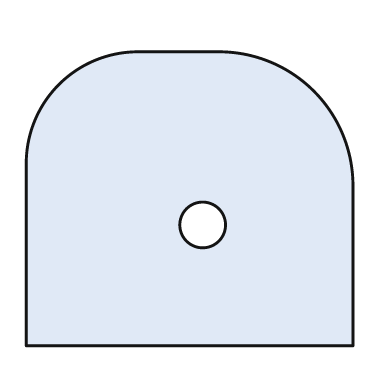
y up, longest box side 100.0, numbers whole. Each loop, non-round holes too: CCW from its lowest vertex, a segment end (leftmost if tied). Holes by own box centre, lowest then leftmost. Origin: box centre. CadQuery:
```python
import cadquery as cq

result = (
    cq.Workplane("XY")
    .moveTo(-50.0, -45.0)
    .lineTo(50.0, -45.0)
    .lineTo(50.0, 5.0)
    .threePointArc((38.0, 33.0), (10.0, 45.0))
    .lineTo(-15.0, 45.0)
    .threePointArc((-40.0, 35.0), (-50.0, 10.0))
    .close()
    .moveTo(4.0, -8.0)
    .circle(7.0)
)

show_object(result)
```